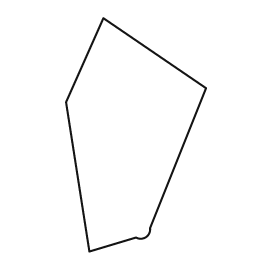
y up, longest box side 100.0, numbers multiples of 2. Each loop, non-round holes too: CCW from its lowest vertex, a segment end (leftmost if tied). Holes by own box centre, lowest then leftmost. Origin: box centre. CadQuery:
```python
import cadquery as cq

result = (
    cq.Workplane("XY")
    .moveTo(-20.0, -50.0)
    .lineTo(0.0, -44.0)
    .threePointArc((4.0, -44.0), (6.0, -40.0))
    .lineTo(30.0, 20.0)
    .lineTo(-14.0, 50.0)
    .lineTo(-30.0, 14.0)
    .close()
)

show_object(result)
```